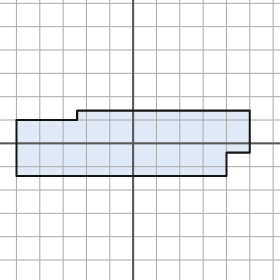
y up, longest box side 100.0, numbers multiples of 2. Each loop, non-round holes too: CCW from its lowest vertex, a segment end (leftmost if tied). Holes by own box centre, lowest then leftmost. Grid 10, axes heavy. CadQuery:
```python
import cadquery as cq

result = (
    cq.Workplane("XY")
    .moveTo(-50.0, -14.0)
    .lineTo(40.0, -14.0)
    .lineTo(40.0, -4.0)
    .lineTo(50.0, -4.0)
    .lineTo(50.0, 14.0)
    .lineTo(-24.0, 14.0)
    .lineTo(-24.0, 10.0)
    .lineTo(-50.0, 10.0)
    .close()
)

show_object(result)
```